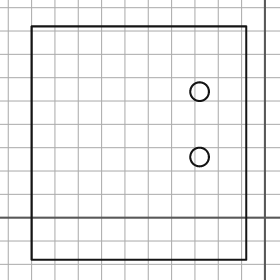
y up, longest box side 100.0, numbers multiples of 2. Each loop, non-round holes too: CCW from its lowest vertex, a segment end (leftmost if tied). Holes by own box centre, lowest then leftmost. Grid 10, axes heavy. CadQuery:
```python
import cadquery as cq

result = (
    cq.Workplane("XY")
    .moveTo(-100.0, -18.0)
    .lineTo(-8.0, -18.0)
    .lineTo(-8.0, 82.0)
    .lineTo(-100.0, 82.0)
    .close()
    .moveTo(-28.0, 26.0)
    .circle(4.0)
    .moveTo(-28.0, 54.0)
    .circle(4.0)
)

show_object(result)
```